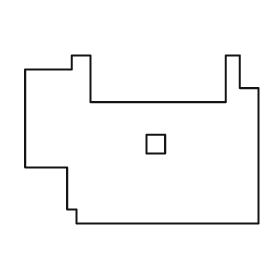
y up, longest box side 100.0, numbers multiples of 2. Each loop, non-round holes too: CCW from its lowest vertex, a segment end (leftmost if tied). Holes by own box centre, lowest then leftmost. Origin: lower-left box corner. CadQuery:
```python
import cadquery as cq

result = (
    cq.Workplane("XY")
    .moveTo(22.0, 0.0)
    .lineTo(100.0, 0.0)
    .lineTo(100.0, 58.0)
    .lineTo(92.0, 58.0)
    .lineTo(92.0, 72.0)
    .lineTo(86.0, 72.0)
    .lineTo(86.0, 52.0)
    .lineTo(28.0, 52.0)
    .lineTo(28.0, 72.0)
    .lineTo(20.0, 72.0)
    .lineTo(20.0, 66.0)
    .lineTo(0.0, 66.0)
    .lineTo(0.0, 24.0)
    .lineTo(18.0, 24.0)
    .lineTo(18.0, 6.0)
    .lineTo(22.0, 6.0)
    .close()
    .moveTo(52.0, 30.0)
    .lineTo(60.0, 30.0)
    .lineTo(60.0, 38.0)
    .lineTo(52.0, 38.0)
    .close()
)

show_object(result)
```